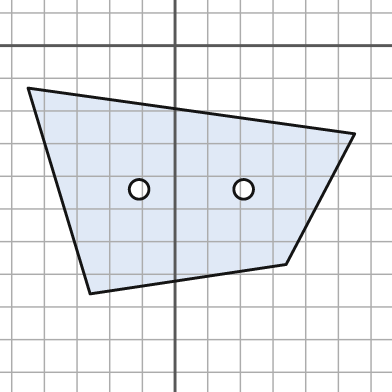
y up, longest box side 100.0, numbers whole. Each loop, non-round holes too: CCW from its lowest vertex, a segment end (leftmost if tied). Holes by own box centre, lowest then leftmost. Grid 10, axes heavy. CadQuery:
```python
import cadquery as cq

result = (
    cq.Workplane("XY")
    .moveTo(-26.0, -76.0)
    .lineTo(34.0, -67.0)
    .lineTo(55.0, -27.0)
    .lineTo(-45.0, -13.0)
    .close()
    .moveTo(-11.0, -44.0)
    .circle(3.0)
    .moveTo(21.0, -44.0)
    .circle(3.0)
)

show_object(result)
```